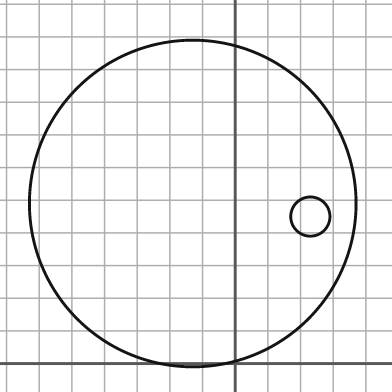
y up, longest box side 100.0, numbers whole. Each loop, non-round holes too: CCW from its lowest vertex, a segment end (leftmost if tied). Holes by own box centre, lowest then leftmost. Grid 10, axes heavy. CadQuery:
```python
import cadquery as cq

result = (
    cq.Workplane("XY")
    .moveTo(-13.0, 49.0)
    .circle(50.0)
    .moveTo(23.0, 45.0)
    .circle(6.0)
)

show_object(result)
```